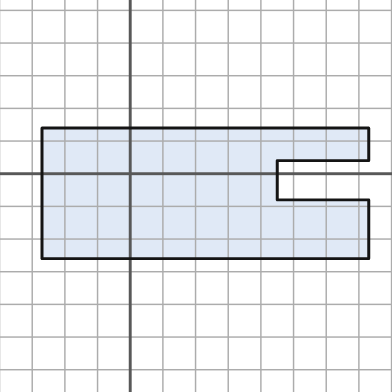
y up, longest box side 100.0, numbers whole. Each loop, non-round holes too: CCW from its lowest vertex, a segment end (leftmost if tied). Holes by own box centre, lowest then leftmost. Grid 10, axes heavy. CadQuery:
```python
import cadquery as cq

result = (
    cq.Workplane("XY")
    .moveTo(-27.0, -26.0)
    .lineTo(73.0, -26.0)
    .lineTo(73.0, -8.0)
    .lineTo(45.0, -8.0)
    .lineTo(45.0, 4.0)
    .lineTo(73.0, 4.0)
    .lineTo(73.0, 14.0)
    .lineTo(-27.0, 14.0)
    .close()
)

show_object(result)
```